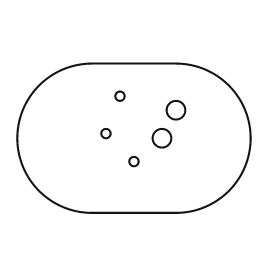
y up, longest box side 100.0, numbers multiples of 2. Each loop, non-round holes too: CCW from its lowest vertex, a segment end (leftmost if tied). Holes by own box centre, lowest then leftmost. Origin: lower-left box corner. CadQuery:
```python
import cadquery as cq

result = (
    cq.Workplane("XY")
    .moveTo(32.0, 0.0)
    .lineTo(68.0, 0.0)
    .threePointArc((100.0, 32.0), (68.0, 64.0))
    .lineTo(32.0, 64.0)
    .threePointArc((0.0, 32.0), (32.0, 0.0))
    .close()
    .moveTo(50.0, 22.0)
    .circle(2.0)
    .moveTo(62.0, 32.0)
    .circle(4.0)
    .moveTo(38.0, 34.0)
    .circle(2.0)
    .moveTo(68.0, 44.0)
    .circle(4.0)
    .moveTo(44.0, 50.0)
    .circle(2.0)
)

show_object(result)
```